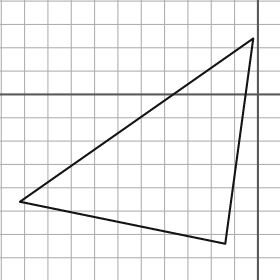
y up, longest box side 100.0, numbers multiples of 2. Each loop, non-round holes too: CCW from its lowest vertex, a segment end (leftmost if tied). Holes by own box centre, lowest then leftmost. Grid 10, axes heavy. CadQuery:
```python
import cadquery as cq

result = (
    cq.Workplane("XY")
    .moveTo(-14.0, -64.0)
    .lineTo(-2.0, 24.0)
    .lineTo(-102.0, -46.0)
    .close()
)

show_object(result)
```